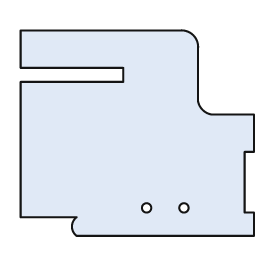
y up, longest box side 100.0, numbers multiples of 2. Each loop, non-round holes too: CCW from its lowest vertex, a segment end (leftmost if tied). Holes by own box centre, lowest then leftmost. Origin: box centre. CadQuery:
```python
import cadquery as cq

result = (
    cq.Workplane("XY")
    .moveTo(-26.0, -44.0)
    .lineTo(50.0, -44.0)
    .lineTo(50.0, -34.0)
    .lineTo(46.0, -34.0)
    .lineTo(46.0, -8.0)
    .lineTo(50.0, -8.0)
    .lineTo(50.0, 8.0)
    .lineTo(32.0, 8.0)
    .threePointArc((28.0, 10.0), (26.0, 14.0))
    .lineTo(26.0, 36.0)
    .threePointArc((24.0, 42.0), (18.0, 44.0))
    .lineTo(-50.0, 44.0)
    .lineTo(-50.0, 28.0)
    .lineTo(-6.0, 28.0)
    .lineTo(-6.0, 22.0)
    .lineTo(-50.0, 22.0)
    .lineTo(-50.0, -36.0)
    .lineTo(-26.0, -36.0)
    .threePointArc((-28.0, -40.0), (-26.0, -44.0))
    .close()
    .moveTo(4.0, -32.0)
    .circle(2.0)
    .moveTo(20.0, -32.0)
    .circle(2.0)
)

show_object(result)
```